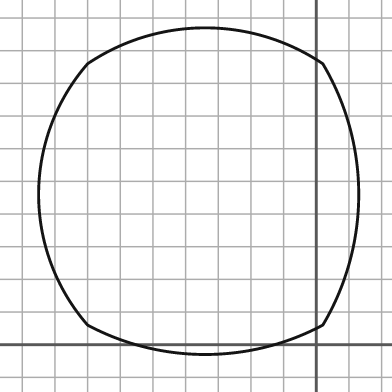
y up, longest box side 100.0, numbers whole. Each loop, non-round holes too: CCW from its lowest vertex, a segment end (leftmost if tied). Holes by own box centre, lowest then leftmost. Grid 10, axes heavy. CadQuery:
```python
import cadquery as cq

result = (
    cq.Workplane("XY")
    .moveTo(-70.0, 6.0)
    .threePointArc((-34.0, -3.0), (2.0, 6.0))
    .threePointArc((13.0, 46.0), (2.0, 86.0))
    .threePointArc((-34.0, 97.0), (-70.0, 86.0))
    .threePointArc((-85.0, 46.0), (-70.0, 6.0))
    .close()
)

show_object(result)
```